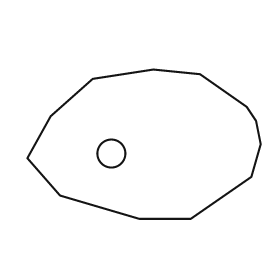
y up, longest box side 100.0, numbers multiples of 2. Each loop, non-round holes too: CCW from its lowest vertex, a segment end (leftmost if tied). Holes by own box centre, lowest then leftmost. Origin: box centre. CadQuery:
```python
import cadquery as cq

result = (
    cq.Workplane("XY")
    .moveTo(-2.0, -32.0)
    .lineTo(20.0, -32.0)
    .lineTo(46.0, -14.0)
    .lineTo(50.0, 0.0)
    .lineTo(48.0, 10.0)
    .lineTo(44.0, 16.0)
    .lineTo(24.0, 30.0)
    .lineTo(4.0, 32.0)
    .lineTo(-22.0, 28.0)
    .lineTo(-40.0, 12.0)
    .lineTo(-50.0, -6.0)
    .lineTo(-36.0, -22.0)
    .close()
    .moveTo(-14.0, -4.0)
    .circle(6.0)
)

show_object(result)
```